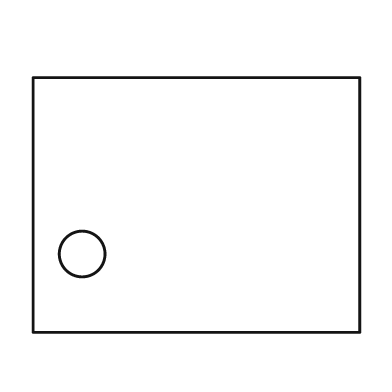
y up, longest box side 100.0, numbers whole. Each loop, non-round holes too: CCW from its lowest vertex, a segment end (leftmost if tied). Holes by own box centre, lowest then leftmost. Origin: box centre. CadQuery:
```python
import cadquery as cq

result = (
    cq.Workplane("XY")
    .moveTo(-50.0, -39.0)
    .lineTo(50.0, -39.0)
    .lineTo(50.0, 39.0)
    .lineTo(-50.0, 39.0)
    .close()
    .moveTo(-35.0, -15.0)
    .circle(7.0)
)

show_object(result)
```